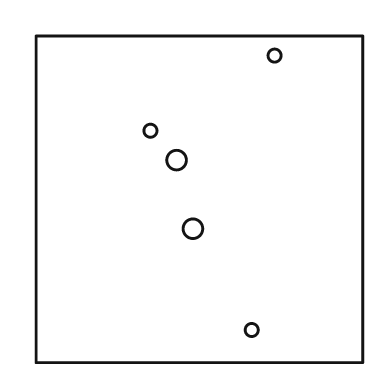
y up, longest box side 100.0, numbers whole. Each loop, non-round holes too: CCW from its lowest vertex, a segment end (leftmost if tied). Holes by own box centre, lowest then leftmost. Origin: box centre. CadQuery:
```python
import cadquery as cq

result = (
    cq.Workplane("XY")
    .moveTo(-50.0, -50.0)
    .lineTo(50.0, -50.0)
    .lineTo(50.0, 50.0)
    .lineTo(-50.0, 50.0)
    .close()
    .moveTo(16.0, -40.0)
    .circle(2.0)
    .moveTo(-2.0, -9.0)
    .circle(3.0)
    .moveTo(-7.0, 12.0)
    .circle(3.0)
    .moveTo(-15.0, 21.0)
    .circle(2.0)
    .moveTo(23.0, 44.0)
    .circle(2.0)
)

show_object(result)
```